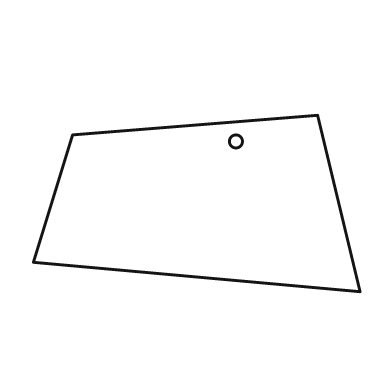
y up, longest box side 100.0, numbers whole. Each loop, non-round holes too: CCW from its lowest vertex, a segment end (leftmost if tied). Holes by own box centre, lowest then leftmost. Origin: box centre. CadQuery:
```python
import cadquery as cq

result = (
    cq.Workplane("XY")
    .moveTo(50.0, -27.0)
    .lineTo(37.0, 27.0)
    .lineTo(-38.0, 21.0)
    .lineTo(-50.0, -18.0)
    .close()
    .moveTo(12.0, 19.0)
    .circle(2.0)
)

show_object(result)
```